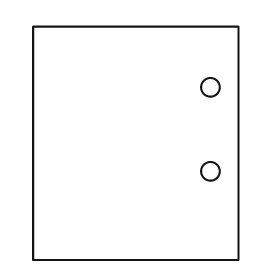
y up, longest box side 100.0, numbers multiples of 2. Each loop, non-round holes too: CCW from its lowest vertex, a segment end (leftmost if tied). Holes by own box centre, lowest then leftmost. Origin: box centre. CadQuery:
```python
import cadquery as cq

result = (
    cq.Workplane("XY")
    .moveTo(-44.0, -50.0)
    .lineTo(44.0, -50.0)
    .lineTo(44.0, 50.0)
    .lineTo(-44.0, 50.0)
    .close()
    .moveTo(32.0, -12.0)
    .circle(4.0)
    .moveTo(32.0, 24.0)
    .circle(4.0)
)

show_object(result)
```